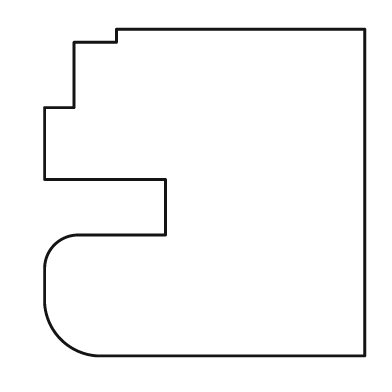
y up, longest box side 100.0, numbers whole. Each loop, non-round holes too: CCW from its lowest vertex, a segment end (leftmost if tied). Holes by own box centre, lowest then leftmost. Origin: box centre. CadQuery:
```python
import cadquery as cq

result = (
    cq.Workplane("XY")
    .moveTo(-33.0, -50.0)
    .lineTo(49.0, -50.0)
    .lineTo(49.0, 50.0)
    .lineTo(-27.0, 50.0)
    .lineTo(-27.0, 46.0)
    .lineTo(-40.0, 46.0)
    .lineTo(-40.0, 26.0)
    .lineTo(-49.0, 26.0)
    .lineTo(-49.0, 4.0)
    .lineTo(-12.0, 4.0)
    .lineTo(-12.0, -13.0)
    .lineTo(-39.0, -13.0)
    .threePointArc((-46.0, -16.0), (-49.0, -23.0))
    .lineTo(-49.0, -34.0)
    .threePointArc((-44.0, -45.0), (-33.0, -50.0))
    .close()
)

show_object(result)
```